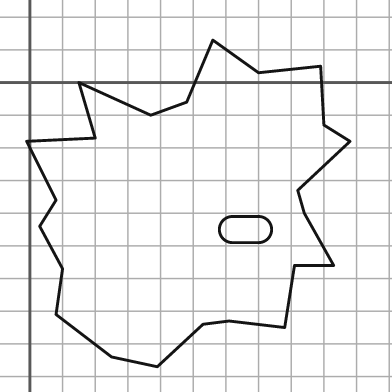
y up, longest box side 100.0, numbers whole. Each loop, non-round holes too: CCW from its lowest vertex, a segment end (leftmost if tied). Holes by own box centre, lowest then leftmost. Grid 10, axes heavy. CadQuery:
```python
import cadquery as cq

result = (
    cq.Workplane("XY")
    .moveTo(39.0, -87.0)
    .lineTo(53.0, -74.0)
    .lineTo(61.0, -73.0)
    .lineTo(78.0, -75.0)
    .lineTo(81.0, -56.0)
    .lineTo(93.0, -56.0)
    .lineTo(84.0, -40.0)
    .lineTo(82.0, -33.0)
    .lineTo(98.0, -18.0)
    .lineTo(90.0, -13.0)
    .lineTo(89.0, 5.0)
    .lineTo(70.0, 3.0)
    .lineTo(56.0, 13.0)
    .lineTo(48.0, -6.0)
    .lineTo(37.0, -10.0)
    .lineTo(15.0, 0.0)
    .lineTo(20.0, -17.0)
    .lineTo(-1.0, -18.0)
    .lineTo(8.0, -36.0)
    .lineTo(3.0, -44.0)
    .lineTo(10.0, -57.0)
    .lineTo(8.0, -71.0)
    .lineTo(25.0, -84.0)
    .close()
    .moveTo(62.0, -49.0)
    .lineTo(70.0, -49.0)
    .threePointArc((74.0, -45.0), (70.0, -41.0))
    .lineTo(62.0, -41.0)
    .threePointArc((58.0, -45.0), (62.0, -49.0))
    .close()
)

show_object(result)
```